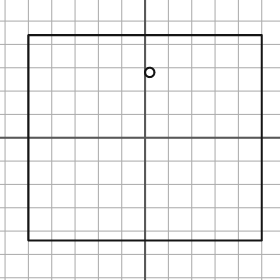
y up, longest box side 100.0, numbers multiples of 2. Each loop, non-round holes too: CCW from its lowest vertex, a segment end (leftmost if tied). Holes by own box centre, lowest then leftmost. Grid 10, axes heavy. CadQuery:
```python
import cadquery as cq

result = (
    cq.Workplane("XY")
    .moveTo(-50.0, -44.0)
    .lineTo(50.0, -44.0)
    .lineTo(50.0, 44.0)
    .lineTo(-50.0, 44.0)
    .close()
    .moveTo(2.0, 28.0)
    .circle(2.0)
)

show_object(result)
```